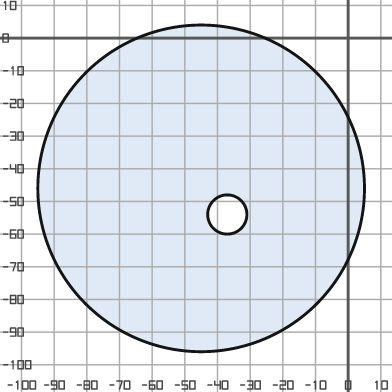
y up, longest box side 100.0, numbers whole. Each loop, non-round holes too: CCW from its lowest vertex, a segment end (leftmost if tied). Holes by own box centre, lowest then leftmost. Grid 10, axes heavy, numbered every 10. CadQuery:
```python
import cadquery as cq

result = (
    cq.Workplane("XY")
    .moveTo(-45.0, -46.0)
    .circle(50.0)
    .moveTo(-37.0, -54.0)
    .circle(6.0)
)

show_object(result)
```